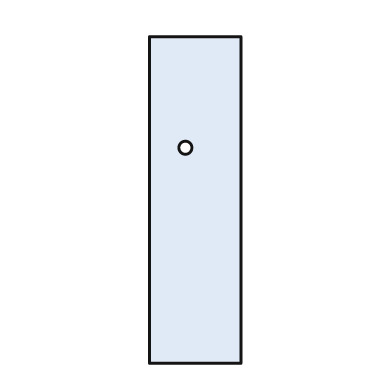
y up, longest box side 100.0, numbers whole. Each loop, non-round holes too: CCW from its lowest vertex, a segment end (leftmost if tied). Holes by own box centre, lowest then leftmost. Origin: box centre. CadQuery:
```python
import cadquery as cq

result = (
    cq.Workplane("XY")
    .moveTo(-14.0, -50.0)
    .lineTo(14.0, -50.0)
    .lineTo(14.0, 50.0)
    .lineTo(-14.0, 50.0)
    .close()
    .moveTo(-3.0, 16.0)
    .circle(2.0)
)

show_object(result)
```